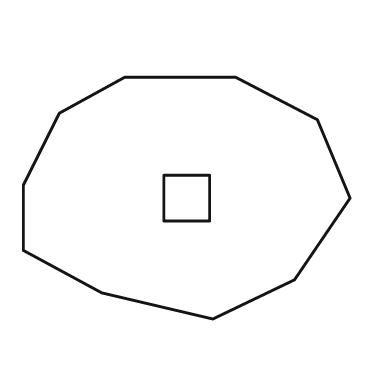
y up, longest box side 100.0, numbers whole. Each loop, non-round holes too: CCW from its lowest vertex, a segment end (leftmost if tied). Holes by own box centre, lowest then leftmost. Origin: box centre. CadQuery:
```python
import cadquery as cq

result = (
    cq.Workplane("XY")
    .moveTo(8.0, -37.0)
    .lineTo(33.0, -25.0)
    .lineTo(50.0, 0.0)
    .lineTo(40.0, 24.0)
    .lineTo(15.0, 37.0)
    .lineTo(-19.0, 37.0)
    .lineTo(-39.0, 26.0)
    .lineTo(-50.0, 4.0)
    .lineTo(-50.0, -16.0)
    .lineTo(-26.0, -29.0)
    .close()
    .moveTo(-7.0, -7.0)
    .lineTo(7.0, -7.0)
    .lineTo(7.0, 7.0)
    .lineTo(-7.0, 7.0)
    .close()
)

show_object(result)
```